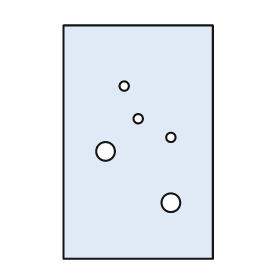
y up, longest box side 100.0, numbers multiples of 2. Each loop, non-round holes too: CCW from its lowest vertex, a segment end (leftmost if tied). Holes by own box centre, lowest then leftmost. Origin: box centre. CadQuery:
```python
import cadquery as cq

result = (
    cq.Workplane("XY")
    .moveTo(-32.0, -50.0)
    .lineTo(32.0, -50.0)
    .lineTo(32.0, 50.0)
    .lineTo(-32.0, 50.0)
    .close()
    .moveTo(14.0, -26.0)
    .circle(4.0)
    .moveTo(-14.0, -4.0)
    .circle(4.0)
    .moveTo(14.0, 2.0)
    .circle(2.0)
    .moveTo(0.0, 10.0)
    .circle(2.0)
    .moveTo(-6.0, 24.0)
    .circle(2.0)
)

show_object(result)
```